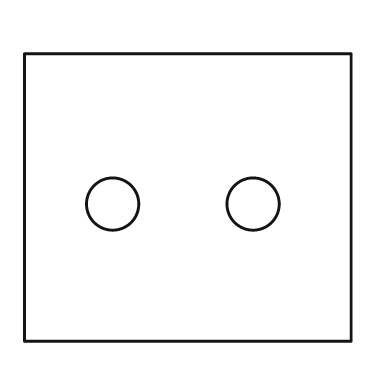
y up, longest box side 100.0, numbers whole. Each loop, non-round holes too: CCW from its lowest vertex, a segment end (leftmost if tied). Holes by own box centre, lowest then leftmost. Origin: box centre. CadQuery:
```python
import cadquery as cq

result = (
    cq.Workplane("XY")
    .moveTo(-50.0, -44.0)
    .lineTo(50.0, -44.0)
    .lineTo(50.0, 44.0)
    .lineTo(-50.0, 44.0)
    .close()
    .moveTo(-23.0, -2.0)
    .circle(8.0)
    .moveTo(20.0, -2.0)
    .circle(8.0)
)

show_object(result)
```